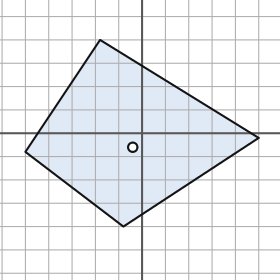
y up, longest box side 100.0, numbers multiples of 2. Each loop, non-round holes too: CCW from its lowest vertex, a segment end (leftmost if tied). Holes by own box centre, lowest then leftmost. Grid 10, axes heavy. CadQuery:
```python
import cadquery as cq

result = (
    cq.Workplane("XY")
    .moveTo(-8.0, -40.0)
    .lineTo(50.0, -2.0)
    .lineTo(-18.0, 40.0)
    .lineTo(-50.0, -8.0)
    .close()
    .moveTo(-4.0, -6.0)
    .circle(2.0)
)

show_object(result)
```